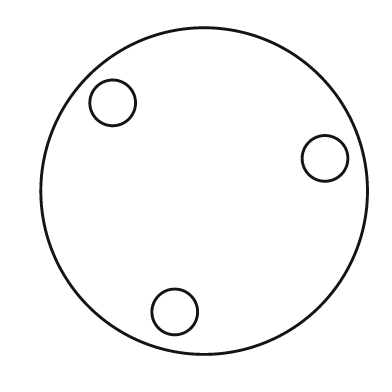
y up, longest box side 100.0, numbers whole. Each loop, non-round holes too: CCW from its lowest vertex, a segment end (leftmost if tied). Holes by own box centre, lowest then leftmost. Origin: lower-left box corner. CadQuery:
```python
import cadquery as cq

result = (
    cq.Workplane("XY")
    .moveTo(50.0, 50.0)
    .circle(50.0)
    .moveTo(41.0, 13.0)
    .circle(7.0)
    .moveTo(87.0, 60.0)
    .circle(7.0)
    .moveTo(22.0, 77.0)
    .circle(7.0)
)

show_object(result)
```